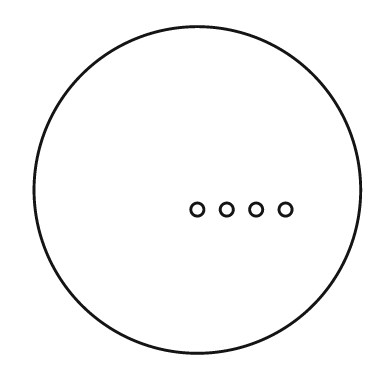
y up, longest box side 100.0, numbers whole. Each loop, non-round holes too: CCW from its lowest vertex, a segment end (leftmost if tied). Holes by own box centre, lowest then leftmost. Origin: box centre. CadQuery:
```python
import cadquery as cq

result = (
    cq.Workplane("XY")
    .moveTo(0.0, 0.0)
    .circle(50.0)
    .moveTo(0.0, -6.0)
    .circle(2.0)
    .moveTo(9.0, -6.0)
    .circle(2.0)
    .moveTo(18.0, -6.0)
    .circle(2.0)
    .moveTo(27.0, -6.0)
    .circle(2.0)
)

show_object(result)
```